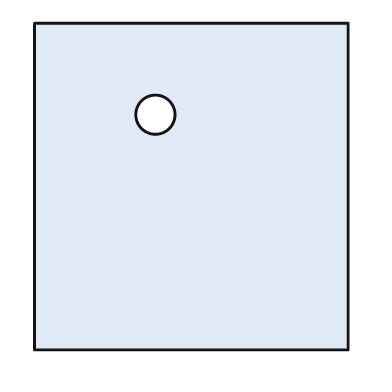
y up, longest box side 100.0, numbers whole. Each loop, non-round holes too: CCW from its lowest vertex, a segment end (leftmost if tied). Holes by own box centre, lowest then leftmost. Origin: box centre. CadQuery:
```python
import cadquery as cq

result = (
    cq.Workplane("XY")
    .moveTo(-48.0, -50.0)
    .lineTo(48.0, -50.0)
    .lineTo(48.0, 50.0)
    .lineTo(-48.0, 50.0)
    .close()
    .moveTo(-11.0, 22.0)
    .circle(6.0)
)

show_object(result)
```